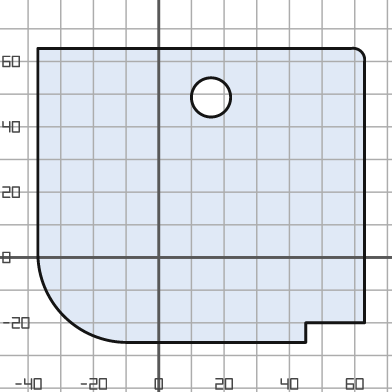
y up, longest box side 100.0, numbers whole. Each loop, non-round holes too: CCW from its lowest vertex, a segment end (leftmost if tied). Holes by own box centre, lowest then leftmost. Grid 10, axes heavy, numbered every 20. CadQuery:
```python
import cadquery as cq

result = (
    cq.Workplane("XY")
    .moveTo(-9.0, -26.0)
    .lineTo(45.0, -26.0)
    .lineTo(45.0, -20.0)
    .lineTo(63.0, -20.0)
    .lineTo(63.0, 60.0)
    .threePointArc((62.0, 63.0), (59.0, 64.0))
    .lineTo(-37.0, 64.0)
    .lineTo(-37.0, 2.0)
    .threePointArc((-29.0, -18.0), (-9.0, -26.0))
    .close()
    .moveTo(16.0, 49.0)
    .circle(6.0)
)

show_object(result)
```